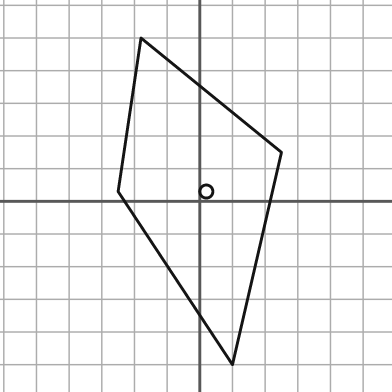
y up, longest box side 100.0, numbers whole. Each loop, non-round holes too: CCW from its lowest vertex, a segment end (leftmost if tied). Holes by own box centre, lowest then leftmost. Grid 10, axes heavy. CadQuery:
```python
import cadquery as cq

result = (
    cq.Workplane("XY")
    .moveTo(10.0, -50.0)
    .lineTo(25.0, 15.0)
    .lineTo(-18.0, 50.0)
    .lineTo(-25.0, 3.0)
    .close()
    .moveTo(2.0, 3.0)
    .circle(2.0)
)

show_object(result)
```